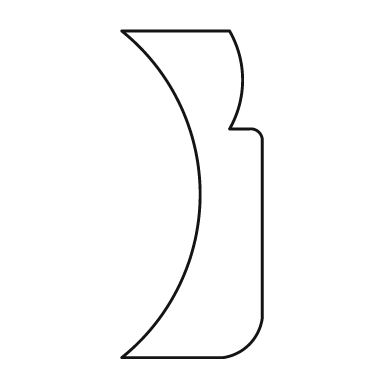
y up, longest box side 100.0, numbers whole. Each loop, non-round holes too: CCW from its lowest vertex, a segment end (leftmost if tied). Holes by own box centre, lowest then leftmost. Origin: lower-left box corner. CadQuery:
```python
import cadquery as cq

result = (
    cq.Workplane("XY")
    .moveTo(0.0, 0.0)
    .lineTo(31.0, 0.0)
    .threePointArc((39.0, 4.0), (43.0, 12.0))
    .lineTo(43.0, 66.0)
    .threePointArc((42.0, 69.0), (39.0, 70.0))
    .lineTo(33.0, 70.0)
    .threePointArc((37.0, 85.0), (33.0, 100.0))
    .lineTo(0.0, 100.0)
    .threePointArc((24.0, 50.0), (0.0, 0.0))
    .close()
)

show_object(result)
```